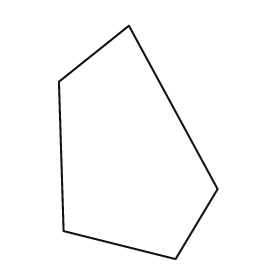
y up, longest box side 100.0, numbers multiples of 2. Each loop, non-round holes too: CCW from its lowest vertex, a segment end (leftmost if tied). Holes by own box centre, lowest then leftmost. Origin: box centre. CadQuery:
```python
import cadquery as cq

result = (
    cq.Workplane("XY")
    .moveTo(16.0, -50.0)
    .lineTo(34.0, -20.0)
    .lineTo(-4.0, 50.0)
    .lineTo(-34.0, 26.0)
    .lineTo(-32.0, -38.0)
    .close()
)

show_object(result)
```